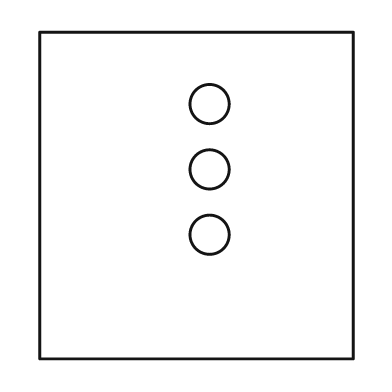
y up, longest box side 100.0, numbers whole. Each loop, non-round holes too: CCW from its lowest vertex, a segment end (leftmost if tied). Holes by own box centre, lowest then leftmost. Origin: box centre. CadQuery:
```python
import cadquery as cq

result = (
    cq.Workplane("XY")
    .moveTo(-48.0, -50.0)
    .lineTo(48.0, -50.0)
    .lineTo(48.0, 50.0)
    .lineTo(-48.0, 50.0)
    .close()
    .moveTo(4.0, -12.0)
    .circle(6.0)
    .moveTo(4.0, 8.0)
    .circle(6.0)
    .moveTo(4.0, 28.0)
    .circle(6.0)
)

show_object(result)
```